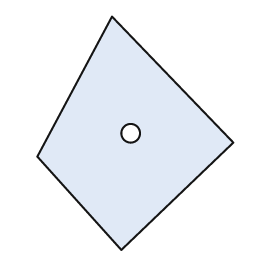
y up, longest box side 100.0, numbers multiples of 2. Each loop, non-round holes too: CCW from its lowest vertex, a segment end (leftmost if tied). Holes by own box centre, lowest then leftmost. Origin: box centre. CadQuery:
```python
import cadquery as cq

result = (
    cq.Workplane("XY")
    .moveTo(-6.0, -50.0)
    .lineTo(42.0, -4.0)
    .lineTo(-10.0, 50.0)
    .lineTo(-42.0, -10.0)
    .close()
    .moveTo(-2.0, 0.0)
    .circle(4.0)
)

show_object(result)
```